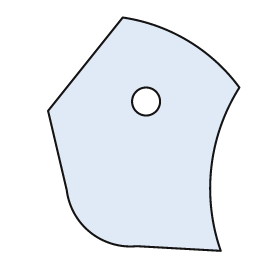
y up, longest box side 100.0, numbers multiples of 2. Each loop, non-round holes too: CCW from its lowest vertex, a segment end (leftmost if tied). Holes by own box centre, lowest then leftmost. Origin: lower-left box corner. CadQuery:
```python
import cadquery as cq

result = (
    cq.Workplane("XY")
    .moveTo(74.0, 0.0)
    .threePointArc((70.0, 36.0), (82.0, 70.0))
    .threePointArc((60.0, 90.0), (32.0, 100.0))
    .lineTo(0.0, 60.0)
    .lineTo(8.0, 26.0)
    .threePointArc((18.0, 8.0), (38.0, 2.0))
    .close()
    .moveTo(42.0, 64.0)
    .circle(6.0)
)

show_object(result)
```